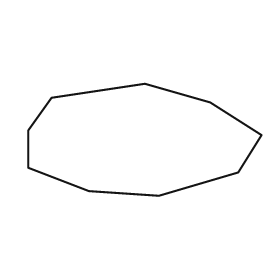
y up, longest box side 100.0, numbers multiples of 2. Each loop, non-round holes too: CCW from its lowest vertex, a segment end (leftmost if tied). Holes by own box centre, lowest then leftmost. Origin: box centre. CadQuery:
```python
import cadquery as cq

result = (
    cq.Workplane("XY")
    .moveTo(6.0, -24.0)
    .lineTo(40.0, -14.0)
    .lineTo(50.0, 2.0)
    .lineTo(28.0, 16.0)
    .lineTo(0.0, 24.0)
    .lineTo(-40.0, 18.0)
    .lineTo(-50.0, 4.0)
    .lineTo(-50.0, -12.0)
    .lineTo(-24.0, -22.0)
    .close()
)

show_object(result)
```